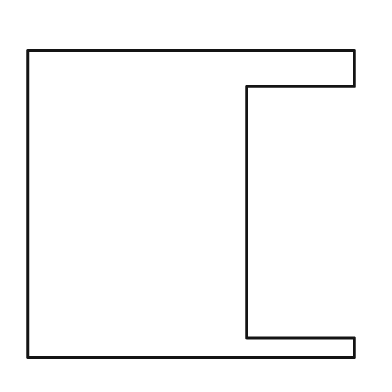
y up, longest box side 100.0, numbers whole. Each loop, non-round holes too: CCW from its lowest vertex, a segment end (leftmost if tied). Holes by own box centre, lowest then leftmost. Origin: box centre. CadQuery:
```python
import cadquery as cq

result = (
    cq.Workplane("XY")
    .moveTo(-50.0, -47.0)
    .lineTo(50.0, -47.0)
    .lineTo(50.0, -41.0)
    .lineTo(17.0, -41.0)
    .lineTo(17.0, 36.0)
    .lineTo(50.0, 36.0)
    .lineTo(50.0, 47.0)
    .lineTo(-50.0, 47.0)
    .close()
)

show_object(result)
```